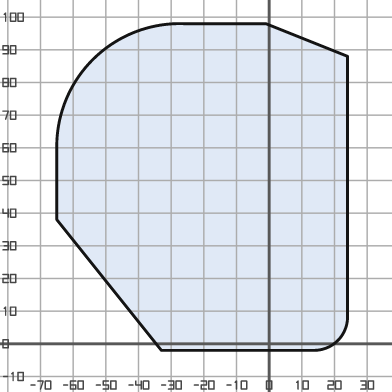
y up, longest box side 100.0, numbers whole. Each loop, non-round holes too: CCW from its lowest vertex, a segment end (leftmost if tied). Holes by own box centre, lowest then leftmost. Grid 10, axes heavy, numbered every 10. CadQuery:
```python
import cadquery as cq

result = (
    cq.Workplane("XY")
    .moveTo(-33.0, -2.0)
    .lineTo(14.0, -2.0)
    .threePointArc((21.0, 1.0), (24.0, 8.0))
    .lineTo(24.0, 88.0)
    .lineTo(-1.0, 98.0)
    .lineTo(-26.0, 98.0)
    .threePointArc((-54.0, 87.0), (-65.0, 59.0))
    .lineTo(-65.0, 38.0)
    .close()
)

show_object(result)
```